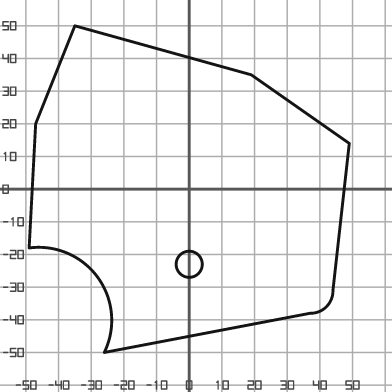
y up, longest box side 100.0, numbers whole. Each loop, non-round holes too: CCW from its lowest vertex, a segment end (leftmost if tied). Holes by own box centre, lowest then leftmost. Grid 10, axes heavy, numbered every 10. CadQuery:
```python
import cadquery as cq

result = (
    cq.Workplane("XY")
    .moveTo(-26.0, -50.0)
    .lineTo(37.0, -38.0)
    .threePointArc((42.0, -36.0), (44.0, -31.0))
    .lineTo(49.0, 14.0)
    .lineTo(19.0, 35.0)
    .lineTo(-35.0, 50.0)
    .lineTo(-47.0, 20.0)
    .lineTo(-49.0, -18.0)
    .threePointArc((-28.0, -27.0), (-26.0, -50.0))
    .close()
    .moveTo(0.0, -23.0)
    .circle(4.0)
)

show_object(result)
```